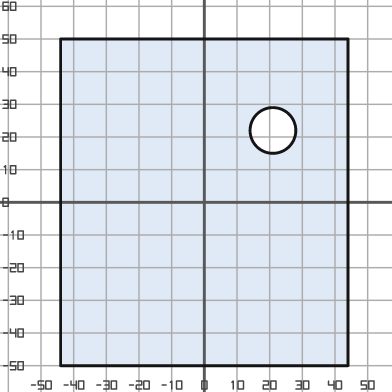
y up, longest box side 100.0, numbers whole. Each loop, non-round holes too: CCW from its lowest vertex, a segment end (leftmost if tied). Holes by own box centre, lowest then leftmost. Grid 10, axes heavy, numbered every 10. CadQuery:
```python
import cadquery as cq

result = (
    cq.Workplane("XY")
    .moveTo(-44.0, -50.0)
    .lineTo(44.0, -50.0)
    .lineTo(44.0, 50.0)
    .lineTo(-44.0, 50.0)
    .close()
    .moveTo(21.0, 22.0)
    .circle(7.0)
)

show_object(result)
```